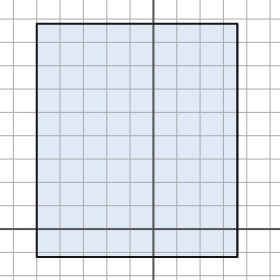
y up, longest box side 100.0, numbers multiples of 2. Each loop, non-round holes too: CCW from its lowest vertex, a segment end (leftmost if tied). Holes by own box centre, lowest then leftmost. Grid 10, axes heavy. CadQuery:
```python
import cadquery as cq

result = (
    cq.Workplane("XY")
    .moveTo(-50.0, -12.0)
    .lineTo(36.0, -12.0)
    .lineTo(36.0, 88.0)
    .lineTo(-50.0, 88.0)
    .close()
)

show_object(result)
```